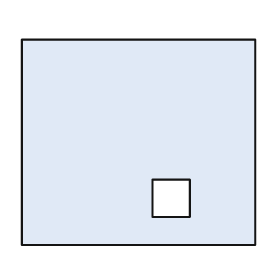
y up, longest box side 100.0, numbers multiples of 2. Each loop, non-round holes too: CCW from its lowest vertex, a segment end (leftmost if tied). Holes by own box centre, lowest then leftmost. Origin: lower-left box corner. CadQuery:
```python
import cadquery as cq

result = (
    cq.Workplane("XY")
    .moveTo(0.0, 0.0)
    .lineTo(100.0, 0.0)
    .lineTo(100.0, 88.0)
    .lineTo(0.0, 88.0)
    .close()
    .moveTo(56.0, 12.0)
    .lineTo(72.0, 12.0)
    .lineTo(72.0, 28.0)
    .lineTo(56.0, 28.0)
    .close()
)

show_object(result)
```